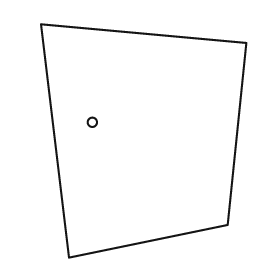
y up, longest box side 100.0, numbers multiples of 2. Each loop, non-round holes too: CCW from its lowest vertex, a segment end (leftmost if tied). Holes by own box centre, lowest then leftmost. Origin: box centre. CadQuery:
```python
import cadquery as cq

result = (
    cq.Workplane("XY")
    .moveTo(-32.0, -50.0)
    .lineTo(36.0, -36.0)
    .lineTo(44.0, 42.0)
    .lineTo(-44.0, 50.0)
    .close()
    .moveTo(-22.0, 8.0)
    .circle(2.0)
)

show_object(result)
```